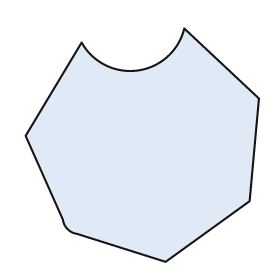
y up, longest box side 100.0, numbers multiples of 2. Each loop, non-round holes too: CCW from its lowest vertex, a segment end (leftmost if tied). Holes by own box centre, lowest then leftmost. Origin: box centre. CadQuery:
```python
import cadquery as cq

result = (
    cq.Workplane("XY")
    .moveTo(10.0, -50.0)
    .lineTo(46.0, -24.0)
    .lineTo(50.0, 20.0)
    .lineTo(18.0, 50.0)
    .threePointArc((-2.0, 32.0), (-26.0, 44.0))
    .lineTo(-50.0, 4.0)
    .lineTo(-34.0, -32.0)
    .threePointArc((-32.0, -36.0), (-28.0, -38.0))
    .close()
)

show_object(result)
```